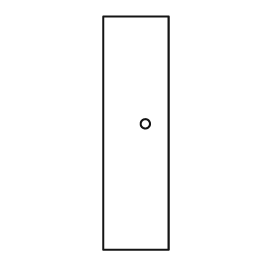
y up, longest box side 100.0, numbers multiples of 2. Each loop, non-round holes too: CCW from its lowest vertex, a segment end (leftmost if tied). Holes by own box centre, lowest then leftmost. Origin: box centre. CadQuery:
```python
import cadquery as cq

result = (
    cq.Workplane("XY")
    .moveTo(-14.0, -50.0)
    .lineTo(14.0, -50.0)
    .lineTo(14.0, 50.0)
    .lineTo(-14.0, 50.0)
    .close()
    .moveTo(4.0, 4.0)
    .circle(2.0)
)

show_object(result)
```